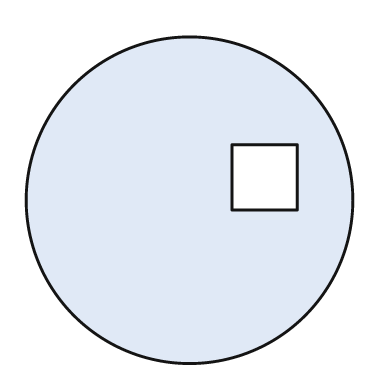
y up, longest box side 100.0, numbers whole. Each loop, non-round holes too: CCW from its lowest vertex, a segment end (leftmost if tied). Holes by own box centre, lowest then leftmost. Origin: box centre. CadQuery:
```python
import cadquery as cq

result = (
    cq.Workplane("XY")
    .moveTo(0.0, 0.0)
    .circle(50.0)
    .moveTo(13.0, -3.0)
    .lineTo(33.0, -3.0)
    .lineTo(33.0, 17.0)
    .lineTo(13.0, 17.0)
    .close()
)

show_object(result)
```